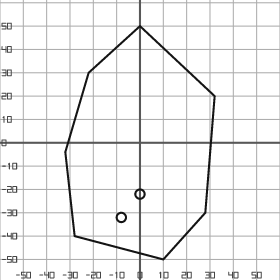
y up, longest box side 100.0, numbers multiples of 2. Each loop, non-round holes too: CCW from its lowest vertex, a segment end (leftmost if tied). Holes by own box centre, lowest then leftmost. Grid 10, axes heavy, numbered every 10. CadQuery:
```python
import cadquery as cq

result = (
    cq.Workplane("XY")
    .moveTo(10.0, -50.0)
    .lineTo(28.0, -30.0)
    .lineTo(32.0, 20.0)
    .lineTo(0.0, 50.0)
    .lineTo(-22.0, 30.0)
    .lineTo(-32.0, -4.0)
    .lineTo(-28.0, -40.0)
    .close()
    .moveTo(-8.0, -32.0)
    .circle(2.0)
    .moveTo(0.0, -22.0)
    .circle(2.0)
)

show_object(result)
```